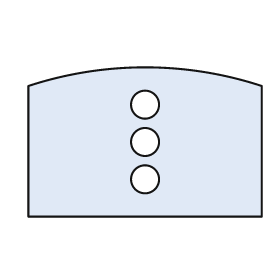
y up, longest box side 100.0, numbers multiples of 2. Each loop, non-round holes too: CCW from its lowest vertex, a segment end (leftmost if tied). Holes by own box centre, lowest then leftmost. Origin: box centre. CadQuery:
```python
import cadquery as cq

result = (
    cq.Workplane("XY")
    .moveTo(-50.0, -32.0)
    .lineTo(50.0, -32.0)
    .lineTo(50.0, 24.0)
    .threePointArc((0.0, 32.0), (-50.0, 24.0))
    .close()
    .moveTo(0.0, -16.0)
    .circle(6.0)
    .moveTo(0.0, 0.0)
    .circle(6.0)
    .moveTo(0.0, 16.0)
    .circle(6.0)
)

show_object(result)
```